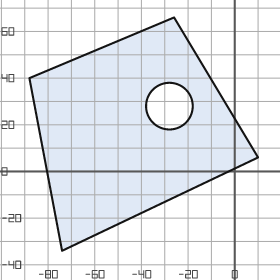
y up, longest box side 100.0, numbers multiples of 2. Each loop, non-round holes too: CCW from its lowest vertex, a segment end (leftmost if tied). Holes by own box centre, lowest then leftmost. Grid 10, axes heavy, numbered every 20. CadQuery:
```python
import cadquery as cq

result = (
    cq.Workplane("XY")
    .moveTo(-74.0, -34.0)
    .lineTo(10.0, 6.0)
    .lineTo(-26.0, 66.0)
    .lineTo(-88.0, 40.0)
    .close()
    .moveTo(-28.0, 28.0)
    .circle(10.0)
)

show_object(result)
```